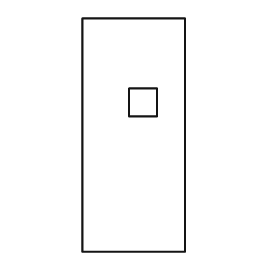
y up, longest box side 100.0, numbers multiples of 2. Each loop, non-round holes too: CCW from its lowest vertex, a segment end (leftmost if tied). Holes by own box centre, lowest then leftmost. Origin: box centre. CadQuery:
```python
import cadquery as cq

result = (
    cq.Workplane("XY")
    .moveTo(-22.0, -50.0)
    .lineTo(22.0, -50.0)
    .lineTo(22.0, 50.0)
    .lineTo(-22.0, 50.0)
    .close()
    .moveTo(-2.0, 8.0)
    .lineTo(10.0, 8.0)
    .lineTo(10.0, 20.0)
    .lineTo(-2.0, 20.0)
    .close()
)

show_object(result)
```